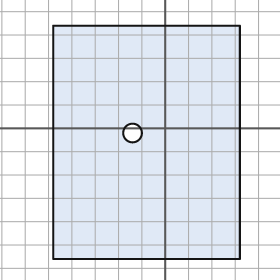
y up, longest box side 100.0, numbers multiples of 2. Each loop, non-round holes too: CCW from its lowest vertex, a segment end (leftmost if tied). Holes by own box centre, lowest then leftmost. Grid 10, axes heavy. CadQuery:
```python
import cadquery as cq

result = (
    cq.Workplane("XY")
    .moveTo(-48.0, -56.0)
    .lineTo(32.0, -56.0)
    .lineTo(32.0, 44.0)
    .lineTo(-48.0, 44.0)
    .close()
    .moveTo(-14.0, -2.0)
    .circle(4.0)
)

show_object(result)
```